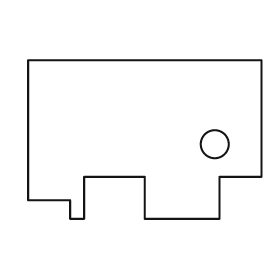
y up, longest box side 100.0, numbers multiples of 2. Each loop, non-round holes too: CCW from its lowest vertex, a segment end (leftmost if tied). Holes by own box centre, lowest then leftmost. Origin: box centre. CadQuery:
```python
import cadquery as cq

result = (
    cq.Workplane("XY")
    .moveTo(-32.0, -34.0)
    .lineTo(-26.0, -34.0)
    .lineTo(-26.0, -16.0)
    .lineTo(0.0, -16.0)
    .lineTo(0.0, -34.0)
    .lineTo(32.0, -34.0)
    .lineTo(32.0, -16.0)
    .lineTo(50.0, -16.0)
    .lineTo(50.0, 34.0)
    .lineTo(-50.0, 34.0)
    .lineTo(-50.0, -26.0)
    .lineTo(-32.0, -26.0)
    .close()
    .moveTo(30.0, -2.0)
    .circle(6.0)
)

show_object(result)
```